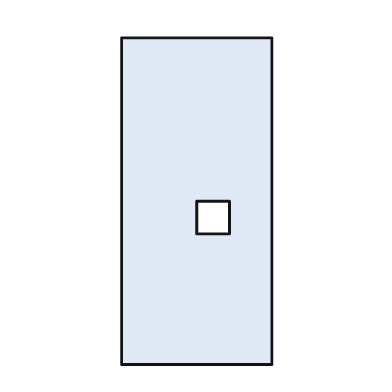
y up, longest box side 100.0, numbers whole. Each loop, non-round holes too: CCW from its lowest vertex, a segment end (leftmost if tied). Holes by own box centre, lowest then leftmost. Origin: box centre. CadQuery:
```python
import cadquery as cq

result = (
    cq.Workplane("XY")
    .moveTo(-23.0, -50.0)
    .lineTo(23.0, -50.0)
    .lineTo(23.0, 50.0)
    .lineTo(-23.0, 50.0)
    .close()
    .moveTo(0.0, -10.0)
    .lineTo(10.0, -10.0)
    .lineTo(10.0, 0.0)
    .lineTo(0.0, 0.0)
    .close()
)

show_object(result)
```